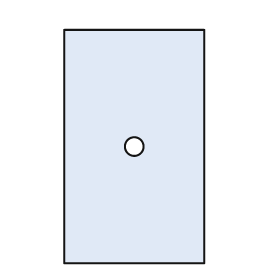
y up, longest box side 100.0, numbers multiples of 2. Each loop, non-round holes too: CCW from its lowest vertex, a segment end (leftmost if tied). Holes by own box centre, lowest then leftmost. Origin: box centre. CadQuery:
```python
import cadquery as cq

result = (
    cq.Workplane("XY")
    .moveTo(-30.0, -50.0)
    .lineTo(30.0, -50.0)
    .lineTo(30.0, 50.0)
    .lineTo(-30.0, 50.0)
    .close()
    .moveTo(0.0, 0.0)
    .circle(4.0)
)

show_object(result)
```